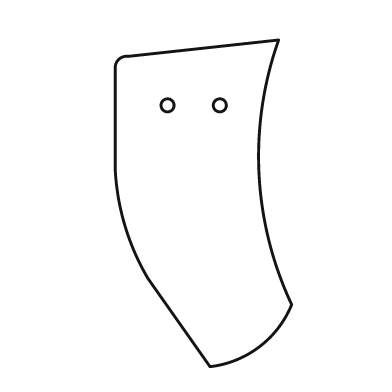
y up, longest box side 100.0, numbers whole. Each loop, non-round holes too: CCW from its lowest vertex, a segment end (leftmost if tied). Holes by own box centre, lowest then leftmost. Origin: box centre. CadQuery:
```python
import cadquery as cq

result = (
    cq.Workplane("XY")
    .moveTo(2.0, -50.0)
    .threePointArc((17.0, -44.0), (27.0, -31.0))
    .threePointArc((17.0, 9.0), (23.0, 50.0))
    .lineTo(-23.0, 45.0)
    .threePointArc((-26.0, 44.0), (-27.0, 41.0))
    .lineTo(-27.0, 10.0)
    .threePointArc((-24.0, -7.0), (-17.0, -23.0))
    .close()
    .moveTo(-11.0, 30.0)
    .circle(2.0)
    .moveTo(5.0, 30.0)
    .circle(2.0)
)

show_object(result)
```